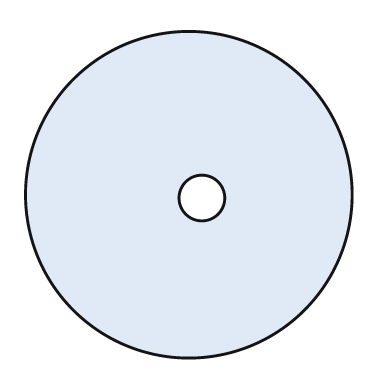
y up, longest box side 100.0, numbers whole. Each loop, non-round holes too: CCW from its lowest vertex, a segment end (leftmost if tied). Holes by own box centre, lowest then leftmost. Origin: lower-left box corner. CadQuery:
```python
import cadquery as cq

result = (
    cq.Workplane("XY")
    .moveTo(50.0, 50.0)
    .circle(50.0)
    .moveTo(54.0, 49.0)
    .circle(7.0)
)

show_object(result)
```